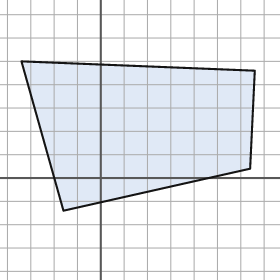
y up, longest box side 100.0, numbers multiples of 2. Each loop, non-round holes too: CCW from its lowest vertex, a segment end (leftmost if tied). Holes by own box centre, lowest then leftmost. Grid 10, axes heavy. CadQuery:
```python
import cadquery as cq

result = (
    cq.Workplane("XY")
    .moveTo(-16.0, -14.0)
    .lineTo(64.0, 4.0)
    .lineTo(66.0, 46.0)
    .lineTo(-34.0, 50.0)
    .close()
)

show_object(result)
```